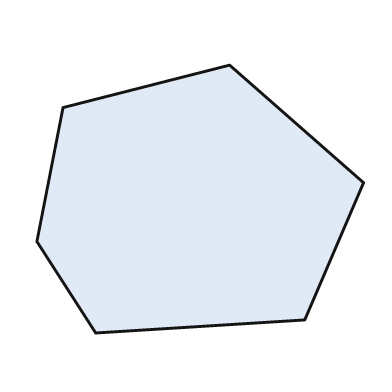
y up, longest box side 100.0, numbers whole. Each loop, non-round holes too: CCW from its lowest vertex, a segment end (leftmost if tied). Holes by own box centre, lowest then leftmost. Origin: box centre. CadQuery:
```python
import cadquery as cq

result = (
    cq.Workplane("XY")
    .moveTo(-32.0, -41.0)
    .lineTo(32.0, -37.0)
    .lineTo(50.0, 5.0)
    .lineTo(9.0, 41.0)
    .lineTo(-42.0, 28.0)
    .lineTo(-50.0, -13.0)
    .close()
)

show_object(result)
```